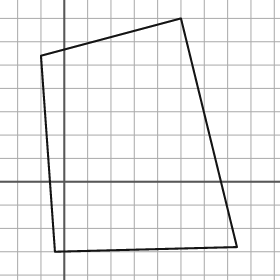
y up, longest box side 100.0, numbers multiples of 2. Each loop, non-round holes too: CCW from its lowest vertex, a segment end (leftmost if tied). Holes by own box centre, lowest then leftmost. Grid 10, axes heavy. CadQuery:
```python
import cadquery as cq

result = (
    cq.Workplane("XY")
    .moveTo(-4.0, -30.0)
    .lineTo(74.0, -28.0)
    .lineTo(50.0, 70.0)
    .lineTo(-10.0, 54.0)
    .close()
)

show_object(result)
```